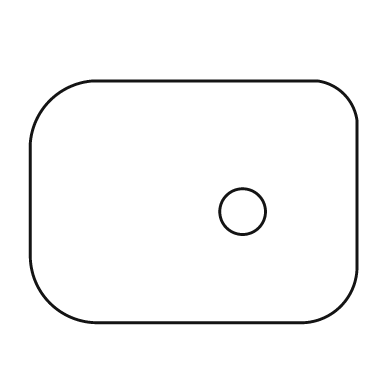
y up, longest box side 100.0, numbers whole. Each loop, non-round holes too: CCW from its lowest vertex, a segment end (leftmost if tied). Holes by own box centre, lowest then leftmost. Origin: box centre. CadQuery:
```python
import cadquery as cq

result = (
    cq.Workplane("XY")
    .moveTo(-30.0, -37.0)
    .lineTo(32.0, -37.0)
    .threePointArc((45.0, -32.0), (50.0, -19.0))
    .lineTo(50.0, 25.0)
    .threePointArc((46.0, 33.0), (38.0, 37.0))
    .lineTo(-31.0, 37.0)
    .threePointArc((-44.0, 31.0), (-50.0, 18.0))
    .lineTo(-50.0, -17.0)
    .threePointArc((-44.0, -31.0), (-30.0, -37.0))
    .close()
    .moveTo(15.0, -3.0)
    .circle(7.0)
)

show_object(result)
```